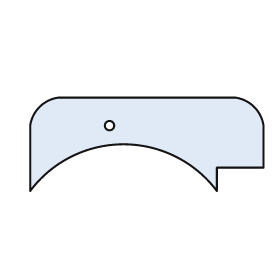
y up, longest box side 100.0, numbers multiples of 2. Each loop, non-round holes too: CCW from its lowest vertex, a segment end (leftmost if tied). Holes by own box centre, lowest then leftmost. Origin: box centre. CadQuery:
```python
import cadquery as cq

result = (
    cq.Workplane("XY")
    .moveTo(-50.0, -20.0)
    .threePointArc((-10.0, 0.0), (30.0, -20.0))
    .lineTo(30.0, -10.0)
    .lineTo(50.0, -10.0)
    .lineTo(50.0, 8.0)
    .threePointArc((46.0, 16.0), (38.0, 20.0))
    .lineTo(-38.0, 20.0)
    .threePointArc((-46.0, 16.0), (-50.0, 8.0))
    .close()
    .moveTo(-16.0, 8.0)
    .circle(2.0)
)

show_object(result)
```